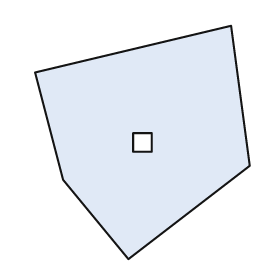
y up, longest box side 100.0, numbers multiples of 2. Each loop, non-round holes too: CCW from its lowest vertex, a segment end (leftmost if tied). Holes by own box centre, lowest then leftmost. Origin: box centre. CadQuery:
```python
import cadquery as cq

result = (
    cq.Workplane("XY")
    .moveTo(-6.0, -50.0)
    .lineTo(46.0, -10.0)
    .lineTo(38.0, 50.0)
    .lineTo(-46.0, 30.0)
    .lineTo(-34.0, -16.0)
    .close()
    .moveTo(-4.0, -4.0)
    .lineTo(4.0, -4.0)
    .lineTo(4.0, 4.0)
    .lineTo(-4.0, 4.0)
    .close()
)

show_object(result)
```